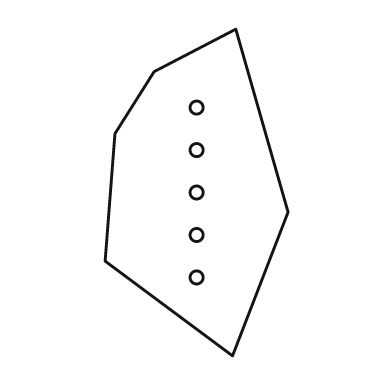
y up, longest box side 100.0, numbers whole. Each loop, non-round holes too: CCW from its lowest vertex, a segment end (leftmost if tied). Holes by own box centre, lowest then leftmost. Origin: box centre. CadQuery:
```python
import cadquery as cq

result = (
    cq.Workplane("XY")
    .moveTo(11.0, -50.0)
    .lineTo(28.0, -6.0)
    .lineTo(12.0, 50.0)
    .lineTo(-13.0, 37.0)
    .lineTo(-25.0, 18.0)
    .lineTo(-28.0, -21.0)
    .close()
    .moveTo(0.0, -26.0)
    .circle(2.0)
    .moveTo(0.0, -13.0)
    .circle(2.0)
    .moveTo(0.0, 0.0)
    .circle(2.0)
    .moveTo(0.0, 13.0)
    .circle(2.0)
    .moveTo(0.0, 26.0)
    .circle(2.0)
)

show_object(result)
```